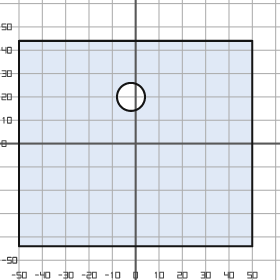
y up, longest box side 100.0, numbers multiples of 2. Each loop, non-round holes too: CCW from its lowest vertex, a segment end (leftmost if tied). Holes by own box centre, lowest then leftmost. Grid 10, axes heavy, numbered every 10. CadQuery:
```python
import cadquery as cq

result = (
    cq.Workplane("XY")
    .moveTo(-50.0, -44.0)
    .lineTo(50.0, -44.0)
    .lineTo(50.0, 44.0)
    .lineTo(-50.0, 44.0)
    .close()
    .moveTo(-2.0, 20.0)
    .circle(6.0)
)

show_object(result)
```